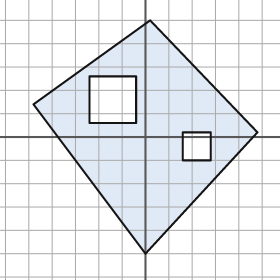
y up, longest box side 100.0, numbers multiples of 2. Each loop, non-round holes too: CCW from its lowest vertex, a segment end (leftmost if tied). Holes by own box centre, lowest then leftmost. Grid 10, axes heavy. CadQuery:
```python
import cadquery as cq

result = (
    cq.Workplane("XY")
    .moveTo(0.0, -50.0)
    .lineTo(48.0, 2.0)
    .lineTo(2.0, 50.0)
    .lineTo(-48.0, 14.0)
    .close()
    .moveTo(16.0, -10.0)
    .lineTo(28.0, -10.0)
    .lineTo(28.0, 2.0)
    .lineTo(16.0, 2.0)
    .close()
    .moveTo(-24.0, 6.0)
    .lineTo(-4.0, 6.0)
    .lineTo(-4.0, 26.0)
    .lineTo(-24.0, 26.0)
    .close()
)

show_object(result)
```